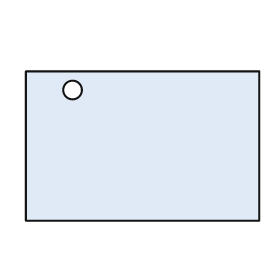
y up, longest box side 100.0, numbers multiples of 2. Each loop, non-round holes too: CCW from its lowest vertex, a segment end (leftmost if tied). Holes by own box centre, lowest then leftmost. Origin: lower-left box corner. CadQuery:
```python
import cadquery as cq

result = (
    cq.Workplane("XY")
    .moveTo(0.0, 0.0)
    .lineTo(100.0, 0.0)
    .lineTo(100.0, 64.0)
    .lineTo(0.0, 64.0)
    .close()
    .moveTo(20.0, 56.0)
    .circle(4.0)
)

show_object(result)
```